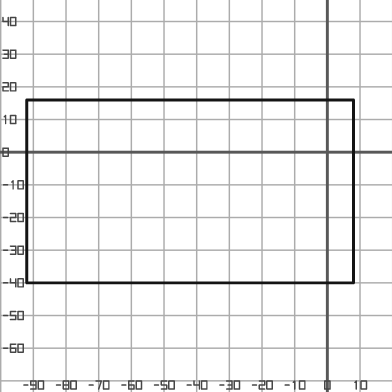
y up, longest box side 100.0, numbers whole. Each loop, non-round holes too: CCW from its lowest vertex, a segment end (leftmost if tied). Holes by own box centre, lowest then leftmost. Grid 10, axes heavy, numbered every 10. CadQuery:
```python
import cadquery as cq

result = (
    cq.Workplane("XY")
    .moveTo(-92.0, -40.0)
    .lineTo(8.0, -40.0)
    .lineTo(8.0, 16.0)
    .lineTo(-92.0, 16.0)
    .close()
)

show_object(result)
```